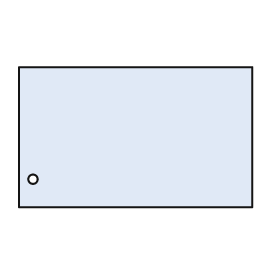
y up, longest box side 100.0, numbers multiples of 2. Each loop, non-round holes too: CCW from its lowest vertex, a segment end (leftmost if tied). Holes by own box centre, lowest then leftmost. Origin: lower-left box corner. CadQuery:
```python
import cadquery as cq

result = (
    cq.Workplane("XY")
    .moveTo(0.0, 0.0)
    .lineTo(100.0, 0.0)
    .lineTo(100.0, 60.0)
    .lineTo(0.0, 60.0)
    .close()
    .moveTo(6.0, 12.0)
    .circle(2.0)
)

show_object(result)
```